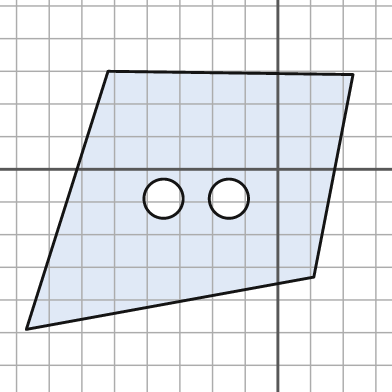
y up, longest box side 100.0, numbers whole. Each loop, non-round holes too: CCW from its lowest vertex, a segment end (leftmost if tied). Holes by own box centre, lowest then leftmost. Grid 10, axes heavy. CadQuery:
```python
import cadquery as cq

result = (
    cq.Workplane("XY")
    .moveTo(-77.0, -49.0)
    .lineTo(11.0, -33.0)
    .lineTo(23.0, 29.0)
    .lineTo(-52.0, 30.0)
    .close()
    .moveTo(-35.0, -9.0)
    .circle(6.0)
    .moveTo(-15.0, -9.0)
    .circle(6.0)
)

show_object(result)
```